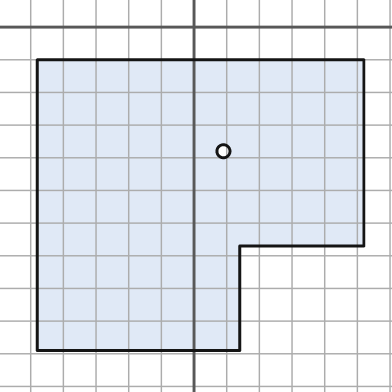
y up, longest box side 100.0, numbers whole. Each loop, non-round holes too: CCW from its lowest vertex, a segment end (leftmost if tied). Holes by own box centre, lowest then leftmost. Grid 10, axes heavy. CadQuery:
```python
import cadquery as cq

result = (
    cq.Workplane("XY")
    .moveTo(-48.0, -99.0)
    .lineTo(14.0, -99.0)
    .lineTo(14.0, -67.0)
    .lineTo(52.0, -67.0)
    .lineTo(52.0, -10.0)
    .lineTo(-48.0, -10.0)
    .close()
    .moveTo(9.0, -38.0)
    .circle(2.0)
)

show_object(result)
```